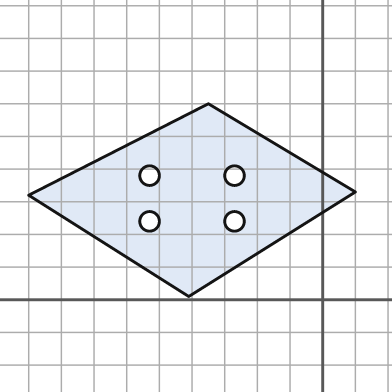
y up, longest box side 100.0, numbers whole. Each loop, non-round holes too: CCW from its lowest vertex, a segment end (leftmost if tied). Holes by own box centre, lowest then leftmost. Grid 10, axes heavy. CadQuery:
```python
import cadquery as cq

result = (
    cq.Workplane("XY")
    .moveTo(-41.0, 1.0)
    .lineTo(10.0, 33.0)
    .lineTo(-35.0, 60.0)
    .lineTo(-90.0, 32.0)
    .close()
    .moveTo(-53.0, 24.0)
    .circle(3.0)
    .moveTo(-27.0, 24.0)
    .circle(3.0)
    .moveTo(-53.0, 38.0)
    .circle(3.0)
    .moveTo(-27.0, 38.0)
    .circle(3.0)
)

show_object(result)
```